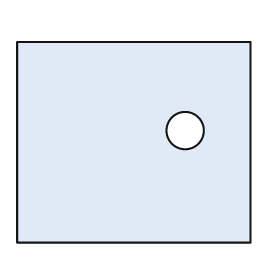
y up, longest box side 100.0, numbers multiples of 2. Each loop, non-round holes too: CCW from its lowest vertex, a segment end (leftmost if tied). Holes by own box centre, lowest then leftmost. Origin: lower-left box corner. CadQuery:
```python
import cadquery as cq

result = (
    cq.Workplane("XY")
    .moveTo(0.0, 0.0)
    .lineTo(100.0, 0.0)
    .lineTo(100.0, 86.0)
    .lineTo(0.0, 86.0)
    .close()
    .moveTo(72.0, 48.0)
    .circle(8.0)
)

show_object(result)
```